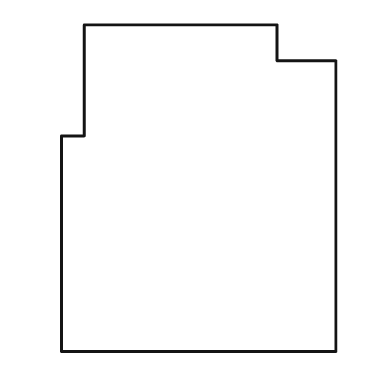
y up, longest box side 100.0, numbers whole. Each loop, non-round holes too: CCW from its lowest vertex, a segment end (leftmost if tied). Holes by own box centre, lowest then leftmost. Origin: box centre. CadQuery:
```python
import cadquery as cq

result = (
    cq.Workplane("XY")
    .moveTo(-42.0, -50.0)
    .lineTo(42.0, -50.0)
    .lineTo(42.0, 39.0)
    .lineTo(24.0, 39.0)
    .lineTo(24.0, 50.0)
    .lineTo(-35.0, 50.0)
    .lineTo(-35.0, 16.0)
    .lineTo(-42.0, 16.0)
    .close()
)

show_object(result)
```